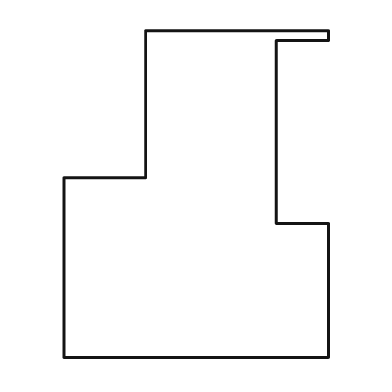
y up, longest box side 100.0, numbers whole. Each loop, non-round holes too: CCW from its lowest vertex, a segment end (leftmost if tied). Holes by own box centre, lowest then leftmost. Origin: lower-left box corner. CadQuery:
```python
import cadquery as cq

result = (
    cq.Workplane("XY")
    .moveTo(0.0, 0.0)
    .lineTo(81.0, 0.0)
    .lineTo(81.0, 41.0)
    .lineTo(65.0, 41.0)
    .lineTo(65.0, 97.0)
    .lineTo(81.0, 97.0)
    .lineTo(81.0, 100.0)
    .lineTo(25.0, 100.0)
    .lineTo(25.0, 55.0)
    .lineTo(0.0, 55.0)
    .close()
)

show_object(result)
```